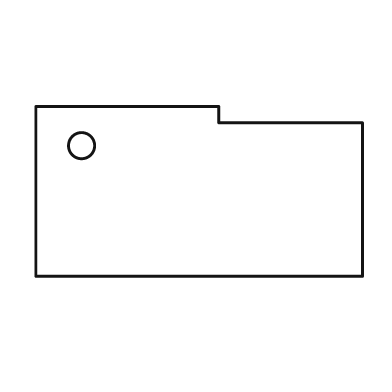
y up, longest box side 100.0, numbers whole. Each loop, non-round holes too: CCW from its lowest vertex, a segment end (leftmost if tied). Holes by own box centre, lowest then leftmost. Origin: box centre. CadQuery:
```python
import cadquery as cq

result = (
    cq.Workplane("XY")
    .moveTo(-50.0, -26.0)
    .lineTo(50.0, -26.0)
    .lineTo(50.0, 21.0)
    .lineTo(6.0, 21.0)
    .lineTo(6.0, 26.0)
    .lineTo(-50.0, 26.0)
    .close()
    .moveTo(-36.0, 14.0)
    .circle(4.0)
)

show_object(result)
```